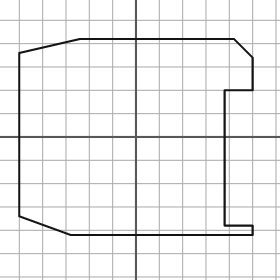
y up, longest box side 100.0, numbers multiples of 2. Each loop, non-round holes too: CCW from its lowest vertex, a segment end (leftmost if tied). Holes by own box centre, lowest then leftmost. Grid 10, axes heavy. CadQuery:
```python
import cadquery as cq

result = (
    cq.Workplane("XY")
    .moveTo(-28.0, -42.0)
    .lineTo(50.0, -42.0)
    .lineTo(50.0, -38.0)
    .lineTo(38.0, -38.0)
    .lineTo(38.0, 20.0)
    .lineTo(50.0, 20.0)
    .lineTo(50.0, 34.0)
    .lineTo(42.0, 42.0)
    .lineTo(-24.0, 42.0)
    .lineTo(-50.0, 36.0)
    .lineTo(-50.0, -34.0)
    .close()
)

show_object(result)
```